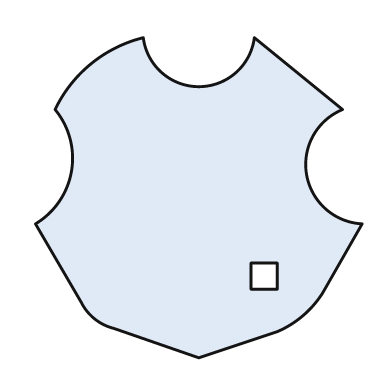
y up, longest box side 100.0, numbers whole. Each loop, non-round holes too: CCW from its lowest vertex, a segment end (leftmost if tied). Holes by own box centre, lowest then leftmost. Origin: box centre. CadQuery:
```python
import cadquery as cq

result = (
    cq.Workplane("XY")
    .moveTo(0.0, -49.0)
    .lineTo(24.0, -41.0)
    .threePointArc((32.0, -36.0), (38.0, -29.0))
    .lineTo(50.0, -8.0)
    .threePointArc((33.0, 7.0), (44.0, 27.0))
    .lineTo(17.0, 49.0)
    .threePointArc((0.0, 34.0), (-17.0, 49.0))
    .threePointArc((-33.0, 41.0), (-44.0, 27.0))
    .threePointArc((-39.0, 8.0), (-50.0, -8.0))
    .lineTo(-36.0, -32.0)
    .threePointArc((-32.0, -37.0), (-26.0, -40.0))
    .close()
    .moveTo(16.0, -28.0)
    .lineTo(24.0, -28.0)
    .lineTo(24.0, -20.0)
    .lineTo(16.0, -20.0)
    .close()
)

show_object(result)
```